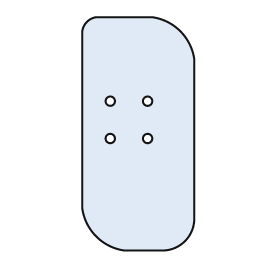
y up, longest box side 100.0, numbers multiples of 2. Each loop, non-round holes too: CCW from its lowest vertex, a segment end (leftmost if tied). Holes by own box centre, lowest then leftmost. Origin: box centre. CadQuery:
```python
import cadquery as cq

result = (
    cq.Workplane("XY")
    .moveTo(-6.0, -50.0)
    .lineTo(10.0, -50.0)
    .threePointArc((20.0, -46.0), (24.0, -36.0))
    .lineTo(24.0, 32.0)
    .threePointArc((18.0, 44.0), (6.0, 50.0))
    .lineTo(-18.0, 50.0)
    .threePointArc((-22.0, 48.0), (-24.0, 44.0))
    .lineTo(-24.0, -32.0)
    .threePointArc((-18.0, -44.0), (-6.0, -50.0))
    .close()
    .moveTo(-12.0, -2.0)
    .circle(2.0)
    .moveTo(4.0, -2.0)
    .circle(2.0)
    .moveTo(-12.0, 14.0)
    .circle(2.0)
    .moveTo(4.0, 14.0)
    .circle(2.0)
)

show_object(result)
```